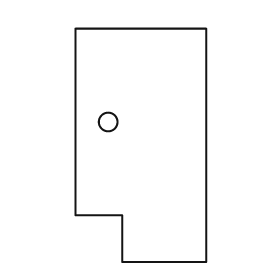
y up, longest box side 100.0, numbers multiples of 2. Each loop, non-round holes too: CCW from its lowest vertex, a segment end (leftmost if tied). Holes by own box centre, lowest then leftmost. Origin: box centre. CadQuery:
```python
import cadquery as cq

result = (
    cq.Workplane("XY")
    .moveTo(-8.0, -50.0)
    .lineTo(28.0, -50.0)
    .lineTo(28.0, 50.0)
    .lineTo(-28.0, 50.0)
    .lineTo(-28.0, -30.0)
    .lineTo(-8.0, -30.0)
    .close()
    .moveTo(-14.0, 10.0)
    .circle(4.0)
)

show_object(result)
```